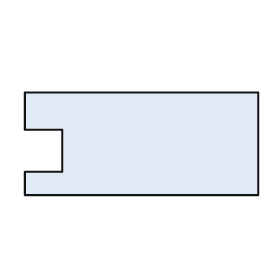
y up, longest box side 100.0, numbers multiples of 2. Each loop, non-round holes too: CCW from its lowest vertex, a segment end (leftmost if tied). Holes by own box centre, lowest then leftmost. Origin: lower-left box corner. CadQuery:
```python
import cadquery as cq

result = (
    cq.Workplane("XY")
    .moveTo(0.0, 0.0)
    .lineTo(100.0, 0.0)
    .lineTo(100.0, 44.0)
    .lineTo(0.0, 44.0)
    .lineTo(0.0, 28.0)
    .lineTo(16.0, 28.0)
    .lineTo(16.0, 10.0)
    .lineTo(0.0, 10.0)
    .close()
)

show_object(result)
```